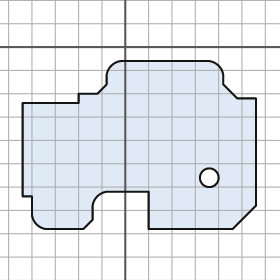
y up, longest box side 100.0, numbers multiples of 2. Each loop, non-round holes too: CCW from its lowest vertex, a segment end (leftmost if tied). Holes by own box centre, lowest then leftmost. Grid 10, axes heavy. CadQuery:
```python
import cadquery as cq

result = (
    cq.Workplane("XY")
    .moveTo(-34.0, -78.0)
    .lineTo(-18.0, -78.0)
    .lineTo(-14.0, -74.0)
    .lineTo(-14.0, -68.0)
    .threePointArc((-12.0, -64.0), (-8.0, -62.0))
    .lineTo(10.0, -62.0)
    .lineTo(10.0, -78.0)
    .lineTo(46.0, -78.0)
    .lineTo(56.0, -68.0)
    .lineTo(56.0, -22.0)
    .lineTo(48.0, -22.0)
    .lineTo(42.0, -16.0)
    .lineTo(42.0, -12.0)
    .threePointArc((40.0, -8.0), (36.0, -6.0))
    .lineTo(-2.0, -6.0)
    .threePointArc((-6.0, -8.0), (-8.0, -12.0))
    .lineTo(-8.0, -16.0)
    .lineTo(-12.0, -20.0)
    .lineTo(-20.0, -20.0)
    .lineTo(-20.0, -24.0)
    .lineTo(-44.0, -24.0)
    .lineTo(-44.0, -64.0)
    .lineTo(-40.0, -64.0)
    .lineTo(-40.0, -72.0)
    .threePointArc((-38.0, -76.0), (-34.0, -78.0))
    .close()
    .moveTo(36.0, -56.0)
    .circle(4.0)
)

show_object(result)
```